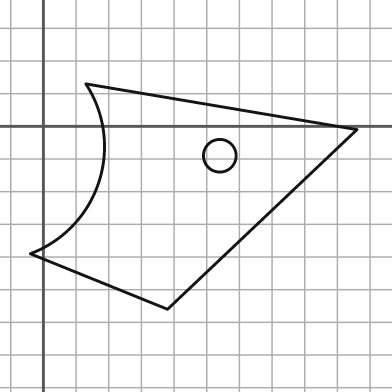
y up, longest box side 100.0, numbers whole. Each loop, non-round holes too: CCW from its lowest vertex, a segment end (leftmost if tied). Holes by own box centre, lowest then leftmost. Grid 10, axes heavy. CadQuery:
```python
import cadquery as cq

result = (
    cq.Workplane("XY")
    .moveTo(38.0, -56.0)
    .lineTo(96.0, -1.0)
    .lineTo(13.0, 13.0)
    .threePointArc((17.0, -17.0), (-4.0, -39.0))
    .close()
    .moveTo(54.0, -9.0)
    .circle(5.0)
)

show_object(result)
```